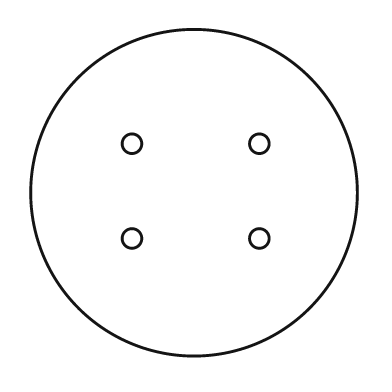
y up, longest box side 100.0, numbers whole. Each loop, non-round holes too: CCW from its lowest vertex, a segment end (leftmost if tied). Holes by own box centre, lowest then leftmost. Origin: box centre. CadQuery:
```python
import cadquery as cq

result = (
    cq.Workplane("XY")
    .moveTo(0.0, 0.0)
    .circle(50.0)
    .moveTo(-19.0, -14.0)
    .circle(3.0)
    .moveTo(20.0, -14.0)
    .circle(3.0)
    .moveTo(-19.0, 15.0)
    .circle(3.0)
    .moveTo(20.0, 15.0)
    .circle(3.0)
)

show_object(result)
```